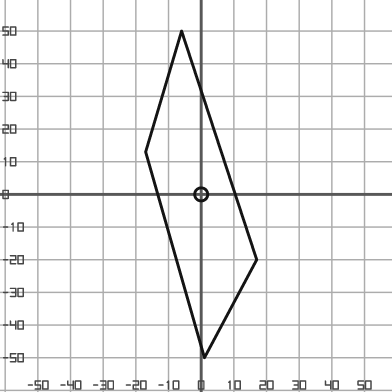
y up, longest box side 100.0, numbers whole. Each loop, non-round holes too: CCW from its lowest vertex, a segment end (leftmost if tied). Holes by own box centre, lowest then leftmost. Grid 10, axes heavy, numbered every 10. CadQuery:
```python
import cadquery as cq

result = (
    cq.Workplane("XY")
    .moveTo(1.0, -50.0)
    .lineTo(17.0, -20.0)
    .lineTo(-6.0, 50.0)
    .lineTo(-17.0, 13.0)
    .close()
    .moveTo(0.0, 0.0)
    .circle(2.0)
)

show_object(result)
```